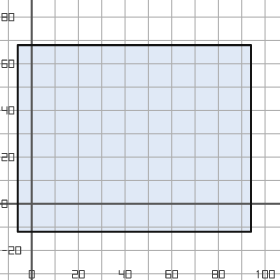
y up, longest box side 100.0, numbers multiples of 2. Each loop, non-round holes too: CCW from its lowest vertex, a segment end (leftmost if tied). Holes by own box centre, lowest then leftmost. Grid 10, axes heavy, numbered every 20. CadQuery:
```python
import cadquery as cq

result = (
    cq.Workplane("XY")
    .moveTo(-6.0, -12.0)
    .lineTo(94.0, -12.0)
    .lineTo(94.0, 68.0)
    .lineTo(-6.0, 68.0)
    .close()
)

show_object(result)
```